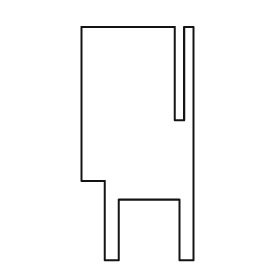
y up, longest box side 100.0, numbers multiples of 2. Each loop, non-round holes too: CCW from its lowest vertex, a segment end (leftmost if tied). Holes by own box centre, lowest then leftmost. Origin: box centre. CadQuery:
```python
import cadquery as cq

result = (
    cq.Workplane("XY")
    .moveTo(-14.0, -50.0)
    .lineTo(-8.0, -50.0)
    .lineTo(-8.0, -24.0)
    .lineTo(18.0, -24.0)
    .lineTo(18.0, -50.0)
    .lineTo(24.0, -50.0)
    .lineTo(24.0, 50.0)
    .lineTo(20.0, 50.0)
    .lineTo(20.0, 10.0)
    .lineTo(16.0, 10.0)
    .lineTo(16.0, 50.0)
    .lineTo(-24.0, 50.0)
    .lineTo(-24.0, -16.0)
    .lineTo(-14.0, -16.0)
    .close()
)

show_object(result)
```